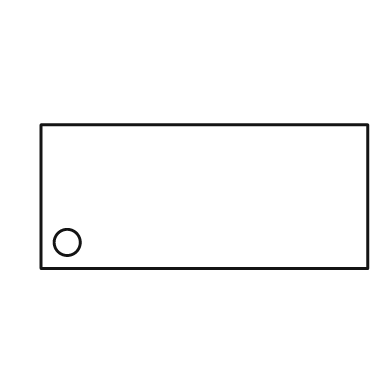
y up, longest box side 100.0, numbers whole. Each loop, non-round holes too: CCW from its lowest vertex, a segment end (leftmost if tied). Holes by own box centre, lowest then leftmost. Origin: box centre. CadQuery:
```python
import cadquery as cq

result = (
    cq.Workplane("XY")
    .moveTo(-50.0, -22.0)
    .lineTo(50.0, -22.0)
    .lineTo(50.0, 22.0)
    .lineTo(-50.0, 22.0)
    .close()
    .moveTo(-42.0, -14.0)
    .circle(4.0)
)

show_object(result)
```